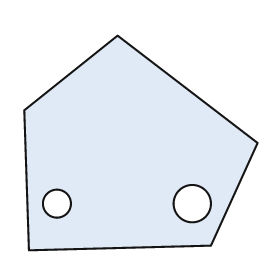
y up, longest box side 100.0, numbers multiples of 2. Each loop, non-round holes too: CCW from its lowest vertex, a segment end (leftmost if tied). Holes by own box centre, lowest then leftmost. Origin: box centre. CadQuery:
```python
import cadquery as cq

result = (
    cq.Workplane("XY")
    .moveTo(-48.0, -46.0)
    .lineTo(30.0, -44.0)
    .lineTo(50.0, 0.0)
    .lineTo(-10.0, 46.0)
    .lineTo(-50.0, 14.0)
    .close()
    .moveTo(-36.0, -26.0)
    .circle(6.0)
    .moveTo(22.0, -26.0)
    .circle(8.0)
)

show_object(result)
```